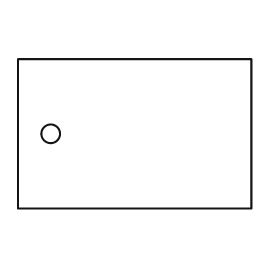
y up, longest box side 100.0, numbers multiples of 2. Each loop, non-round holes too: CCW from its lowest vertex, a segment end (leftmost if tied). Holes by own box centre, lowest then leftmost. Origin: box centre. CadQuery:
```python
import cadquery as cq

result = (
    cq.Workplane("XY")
    .moveTo(-50.0, -32.0)
    .lineTo(50.0, -32.0)
    .lineTo(50.0, 32.0)
    .lineTo(-50.0, 32.0)
    .close()
    .moveTo(-36.0, 0.0)
    .circle(4.0)
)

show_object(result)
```